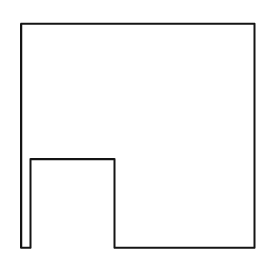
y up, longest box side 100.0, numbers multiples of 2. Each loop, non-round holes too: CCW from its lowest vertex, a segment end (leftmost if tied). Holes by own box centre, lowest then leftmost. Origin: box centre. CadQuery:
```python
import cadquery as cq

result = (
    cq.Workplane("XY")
    .moveTo(-50.0, -48.0)
    .lineTo(-46.0, -48.0)
    .lineTo(-46.0, -10.0)
    .lineTo(-10.0, -10.0)
    .lineTo(-10.0, -48.0)
    .lineTo(50.0, -48.0)
    .lineTo(50.0, 48.0)
    .lineTo(-50.0, 48.0)
    .close()
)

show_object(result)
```